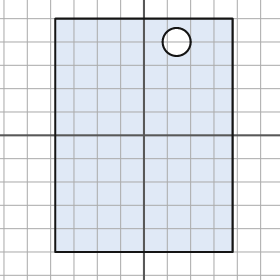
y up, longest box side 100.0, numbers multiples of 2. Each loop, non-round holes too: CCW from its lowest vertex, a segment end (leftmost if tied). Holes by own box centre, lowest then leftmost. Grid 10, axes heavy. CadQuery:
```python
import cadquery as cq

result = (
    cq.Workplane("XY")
    .moveTo(-38.0, -50.0)
    .lineTo(38.0, -50.0)
    .lineTo(38.0, 50.0)
    .lineTo(-38.0, 50.0)
    .close()
    .moveTo(14.0, 40.0)
    .circle(6.0)
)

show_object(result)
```